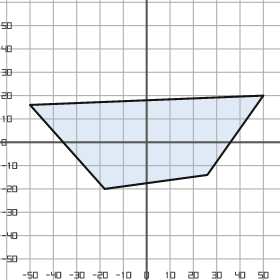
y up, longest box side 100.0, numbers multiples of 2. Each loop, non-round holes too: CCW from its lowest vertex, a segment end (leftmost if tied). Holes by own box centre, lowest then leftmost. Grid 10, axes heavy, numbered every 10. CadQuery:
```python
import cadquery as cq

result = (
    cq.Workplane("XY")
    .moveTo(-18.0, -20.0)
    .lineTo(26.0, -14.0)
    .lineTo(50.0, 20.0)
    .lineTo(-50.0, 16.0)
    .close()
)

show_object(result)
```